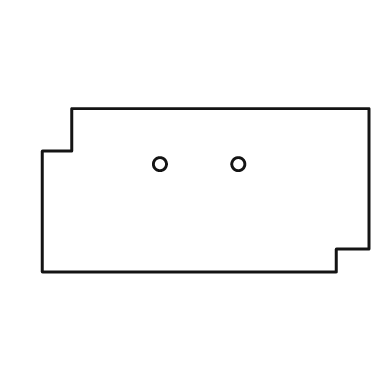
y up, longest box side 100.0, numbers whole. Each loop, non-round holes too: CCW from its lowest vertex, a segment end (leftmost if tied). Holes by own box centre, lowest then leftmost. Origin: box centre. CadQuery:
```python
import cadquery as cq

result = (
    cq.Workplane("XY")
    .moveTo(-50.0, -25.0)
    .lineTo(40.0, -25.0)
    .lineTo(40.0, -18.0)
    .lineTo(50.0, -18.0)
    .lineTo(50.0, 25.0)
    .lineTo(-41.0, 25.0)
    .lineTo(-41.0, 12.0)
    .lineTo(-50.0, 12.0)
    .close()
    .moveTo(-14.0, 8.0)
    .circle(2.0)
    .moveTo(10.0, 8.0)
    .circle(2.0)
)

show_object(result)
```